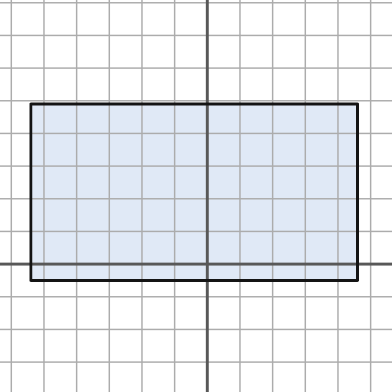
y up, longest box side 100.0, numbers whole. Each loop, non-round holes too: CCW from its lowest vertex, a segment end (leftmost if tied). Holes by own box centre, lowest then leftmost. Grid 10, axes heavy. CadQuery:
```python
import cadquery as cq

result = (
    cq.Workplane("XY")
    .moveTo(-54.0, -5.0)
    .lineTo(46.0, -5.0)
    .lineTo(46.0, 49.0)
    .lineTo(-54.0, 49.0)
    .close()
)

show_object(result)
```